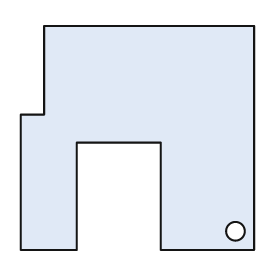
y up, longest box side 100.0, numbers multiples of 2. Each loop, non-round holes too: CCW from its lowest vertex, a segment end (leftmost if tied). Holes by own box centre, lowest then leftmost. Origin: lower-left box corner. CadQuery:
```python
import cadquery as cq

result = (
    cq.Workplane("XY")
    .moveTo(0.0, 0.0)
    .lineTo(24.0, 0.0)
    .lineTo(24.0, 46.0)
    .lineTo(60.0, 46.0)
    .lineTo(60.0, 0.0)
    .lineTo(100.0, 0.0)
    .lineTo(100.0, 96.0)
    .lineTo(10.0, 96.0)
    .lineTo(10.0, 58.0)
    .lineTo(0.0, 58.0)
    .close()
    .moveTo(92.0, 8.0)
    .circle(4.0)
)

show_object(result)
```